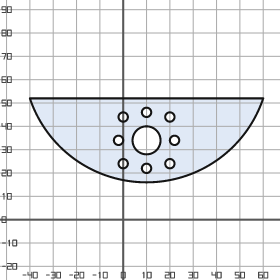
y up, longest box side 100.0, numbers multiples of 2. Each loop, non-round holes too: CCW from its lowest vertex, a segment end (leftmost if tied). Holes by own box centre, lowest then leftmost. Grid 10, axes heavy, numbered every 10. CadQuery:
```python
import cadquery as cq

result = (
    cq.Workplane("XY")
    .moveTo(-40.0, 52.0)
    .threePointArc((10.0, 16.0), (60.0, 52.0))
    .close()
    .moveTo(10.0, 22.0)
    .circle(2.0)
    .moveTo(0.0, 24.0)
    .circle(2.0)
    .moveTo(20.0, 24.0)
    .circle(2.0)
    .moveTo(-2.0, 34.0)
    .circle(2.0)
    .moveTo(10.0, 34.0)
    .circle(6.0)
    .moveTo(22.0, 34.0)
    .circle(2.0)
    .moveTo(0.0, 44.0)
    .circle(2.0)
    .moveTo(20.0, 44.0)
    .circle(2.0)
    .moveTo(10.0, 46.0)
    .circle(2.0)
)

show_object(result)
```